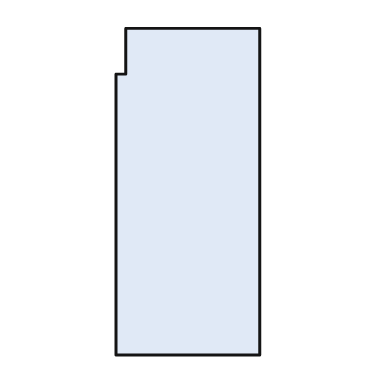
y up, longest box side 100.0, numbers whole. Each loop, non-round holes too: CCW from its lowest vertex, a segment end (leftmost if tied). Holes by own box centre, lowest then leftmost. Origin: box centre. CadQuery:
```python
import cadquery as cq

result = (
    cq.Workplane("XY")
    .moveTo(-22.0, -50.0)
    .lineTo(22.0, -50.0)
    .lineTo(22.0, 50.0)
    .lineTo(-19.0, 50.0)
    .lineTo(-19.0, 36.0)
    .lineTo(-22.0, 36.0)
    .close()
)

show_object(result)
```